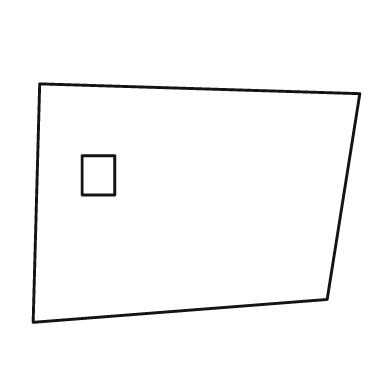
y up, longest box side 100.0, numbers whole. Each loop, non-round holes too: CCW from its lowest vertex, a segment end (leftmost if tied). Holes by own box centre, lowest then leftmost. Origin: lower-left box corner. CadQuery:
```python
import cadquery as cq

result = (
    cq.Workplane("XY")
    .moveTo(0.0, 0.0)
    .lineTo(90.0, 7.0)
    .lineTo(100.0, 70.0)
    .lineTo(2.0, 73.0)
    .close()
    .moveTo(15.0, 39.0)
    .lineTo(25.0, 39.0)
    .lineTo(25.0, 51.0)
    .lineTo(15.0, 51.0)
    .close()
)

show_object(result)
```